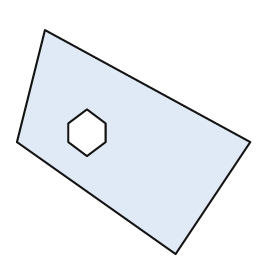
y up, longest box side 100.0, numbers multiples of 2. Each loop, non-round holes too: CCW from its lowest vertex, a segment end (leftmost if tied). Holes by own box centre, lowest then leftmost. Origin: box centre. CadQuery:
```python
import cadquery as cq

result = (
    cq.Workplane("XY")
    .moveTo(18.0, -48.0)
    .lineTo(50.0, 0.0)
    .lineTo(-38.0, 48.0)
    .lineTo(-50.0, 0.0)
    .close()
    .moveTo(-20.0, -6.0)
    .lineTo(-12.0, 0.0)
    .lineTo(-12.0, 8.0)
    .lineTo(-20.0, 14.0)
    .lineTo(-28.0, 8.0)
    .lineTo(-28.0, 0.0)
    .close()
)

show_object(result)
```